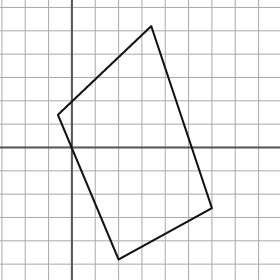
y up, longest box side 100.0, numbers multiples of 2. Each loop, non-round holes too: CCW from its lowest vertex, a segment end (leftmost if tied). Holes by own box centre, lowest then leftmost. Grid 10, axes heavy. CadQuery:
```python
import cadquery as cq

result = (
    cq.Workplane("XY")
    .moveTo(20.0, -48.0)
    .lineTo(60.0, -26.0)
    .lineTo(34.0, 52.0)
    .lineTo(-6.0, 14.0)
    .close()
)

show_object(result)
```